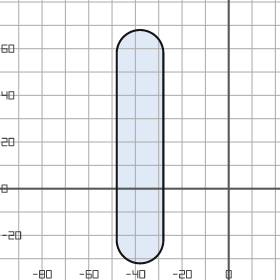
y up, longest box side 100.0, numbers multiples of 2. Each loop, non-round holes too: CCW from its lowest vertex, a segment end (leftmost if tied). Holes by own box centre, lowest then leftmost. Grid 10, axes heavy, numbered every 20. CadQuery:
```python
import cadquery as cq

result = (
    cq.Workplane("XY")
    .moveTo(-48.0, -22.0)
    .threePointArc((-38.0, -32.0), (-28.0, -22.0))
    .lineTo(-28.0, 58.0)
    .threePointArc((-38.0, 68.0), (-48.0, 58.0))
    .close()
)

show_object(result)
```